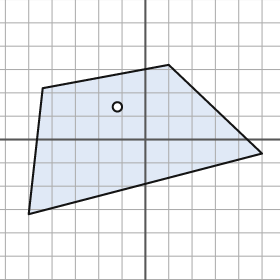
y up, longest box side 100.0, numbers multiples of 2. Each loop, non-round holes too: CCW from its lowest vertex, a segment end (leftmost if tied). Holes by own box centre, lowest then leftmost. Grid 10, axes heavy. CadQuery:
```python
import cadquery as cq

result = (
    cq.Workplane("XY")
    .moveTo(-50.0, -32.0)
    .lineTo(50.0, -6.0)
    .lineTo(10.0, 32.0)
    .lineTo(-44.0, 22.0)
    .close()
    .moveTo(-12.0, 14.0)
    .circle(2.0)
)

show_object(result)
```